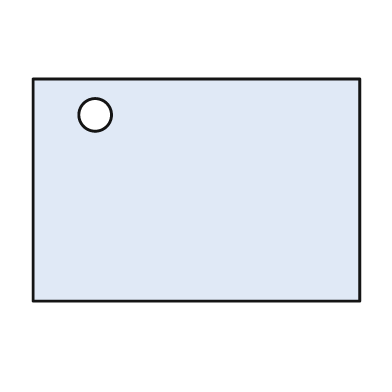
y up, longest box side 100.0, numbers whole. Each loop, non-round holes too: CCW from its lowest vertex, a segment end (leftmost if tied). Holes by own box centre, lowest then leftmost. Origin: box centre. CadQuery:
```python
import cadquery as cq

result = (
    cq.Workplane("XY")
    .moveTo(-50.0, -34.0)
    .lineTo(50.0, -34.0)
    .lineTo(50.0, 34.0)
    .lineTo(-50.0, 34.0)
    .close()
    .moveTo(-31.0, 23.0)
    .circle(5.0)
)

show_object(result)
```